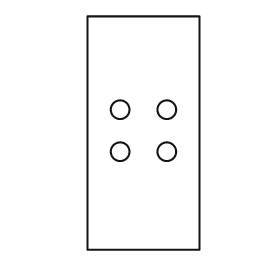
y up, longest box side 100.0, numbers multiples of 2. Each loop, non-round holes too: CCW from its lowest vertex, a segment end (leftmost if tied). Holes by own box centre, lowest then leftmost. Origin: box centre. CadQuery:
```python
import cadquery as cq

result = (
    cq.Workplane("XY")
    .moveTo(-24.0, -50.0)
    .lineTo(24.0, -50.0)
    .lineTo(24.0, 50.0)
    .lineTo(-24.0, 50.0)
    .close()
    .moveTo(-10.0, -8.0)
    .circle(4.0)
    .moveTo(10.0, -8.0)
    .circle(4.0)
    .moveTo(-10.0, 10.0)
    .circle(4.0)
    .moveTo(10.0, 10.0)
    .circle(4.0)
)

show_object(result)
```